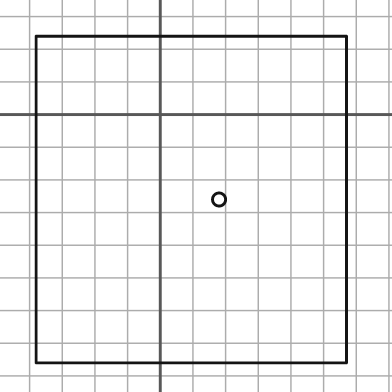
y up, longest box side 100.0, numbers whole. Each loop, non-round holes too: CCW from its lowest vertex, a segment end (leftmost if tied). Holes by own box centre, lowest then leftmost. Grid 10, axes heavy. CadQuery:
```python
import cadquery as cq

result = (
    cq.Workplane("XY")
    .moveTo(-38.0, -76.0)
    .lineTo(57.0, -76.0)
    .lineTo(57.0, 24.0)
    .lineTo(-38.0, 24.0)
    .close()
    .moveTo(18.0, -26.0)
    .circle(2.0)
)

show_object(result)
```